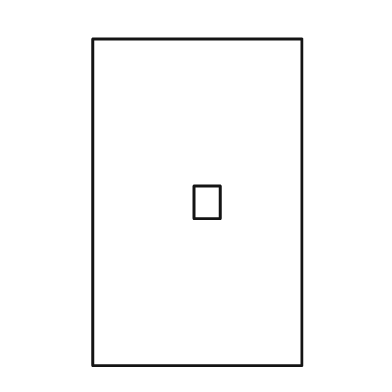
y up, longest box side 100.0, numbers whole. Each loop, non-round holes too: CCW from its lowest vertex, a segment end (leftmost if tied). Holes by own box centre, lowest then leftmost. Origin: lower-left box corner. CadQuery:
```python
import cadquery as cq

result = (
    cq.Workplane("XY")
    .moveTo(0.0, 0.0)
    .lineTo(64.0, 0.0)
    .lineTo(64.0, 100.0)
    .lineTo(0.0, 100.0)
    .close()
    .moveTo(31.0, 45.0)
    .lineTo(39.0, 45.0)
    .lineTo(39.0, 55.0)
    .lineTo(31.0, 55.0)
    .close()
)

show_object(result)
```